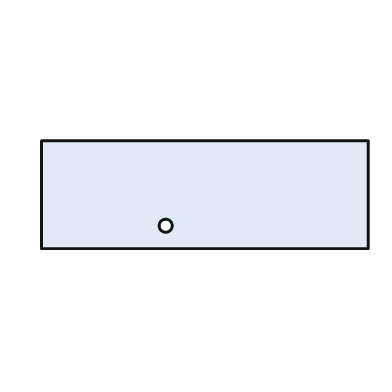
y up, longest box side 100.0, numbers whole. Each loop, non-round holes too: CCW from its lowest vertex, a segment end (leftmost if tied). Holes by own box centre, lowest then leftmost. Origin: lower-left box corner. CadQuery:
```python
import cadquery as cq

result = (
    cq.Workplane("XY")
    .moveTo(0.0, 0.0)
    .lineTo(100.0, 0.0)
    .lineTo(100.0, 33.0)
    .lineTo(0.0, 33.0)
    .close()
    .moveTo(38.0, 7.0)
    .circle(2.0)
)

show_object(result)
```